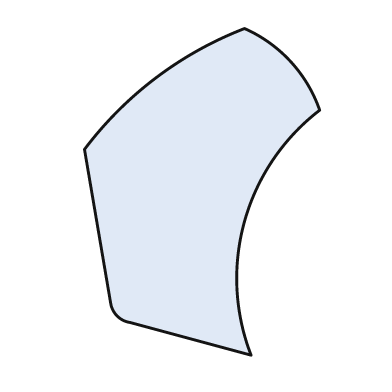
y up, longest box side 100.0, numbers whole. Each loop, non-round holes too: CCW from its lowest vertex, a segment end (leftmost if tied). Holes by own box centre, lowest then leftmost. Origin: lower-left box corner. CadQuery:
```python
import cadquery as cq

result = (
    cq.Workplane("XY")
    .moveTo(51.0, 0.0)
    .threePointArc((49.0, 41.0), (72.0, 75.0))
    .threePointArc((63.0, 90.0), (49.0, 100.0))
    .threePointArc((22.0, 85.0), (0.0, 63.0))
    .lineTo(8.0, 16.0)
    .threePointArc((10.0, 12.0), (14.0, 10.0))
    .close()
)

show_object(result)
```